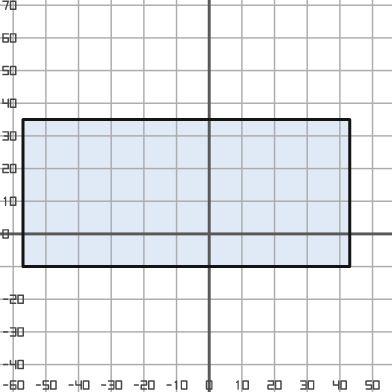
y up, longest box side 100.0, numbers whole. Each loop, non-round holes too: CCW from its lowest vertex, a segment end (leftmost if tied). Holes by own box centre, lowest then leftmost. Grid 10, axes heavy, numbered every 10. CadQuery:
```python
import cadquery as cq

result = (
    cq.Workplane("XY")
    .moveTo(-57.0, -10.0)
    .lineTo(43.0, -10.0)
    .lineTo(43.0, 35.0)
    .lineTo(-57.0, 35.0)
    .close()
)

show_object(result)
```